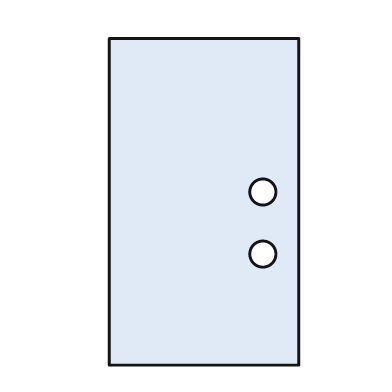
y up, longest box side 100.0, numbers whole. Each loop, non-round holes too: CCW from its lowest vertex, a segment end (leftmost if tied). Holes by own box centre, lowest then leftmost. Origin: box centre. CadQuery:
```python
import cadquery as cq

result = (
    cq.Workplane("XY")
    .moveTo(-29.0, -50.0)
    .lineTo(29.0, -50.0)
    .lineTo(29.0, 50.0)
    .lineTo(-29.0, 50.0)
    .close()
    .moveTo(18.0, -16.0)
    .circle(4.0)
    .moveTo(18.0, 3.0)
    .circle(4.0)
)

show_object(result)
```